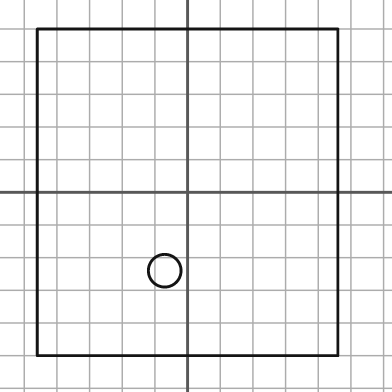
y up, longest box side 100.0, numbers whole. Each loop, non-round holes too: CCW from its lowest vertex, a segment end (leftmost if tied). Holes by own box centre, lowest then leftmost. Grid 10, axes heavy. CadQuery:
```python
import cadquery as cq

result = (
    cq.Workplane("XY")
    .moveTo(-46.0, -50.0)
    .lineTo(46.0, -50.0)
    .lineTo(46.0, 50.0)
    .lineTo(-46.0, 50.0)
    .close()
    .moveTo(-7.0, -24.0)
    .circle(5.0)
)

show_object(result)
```